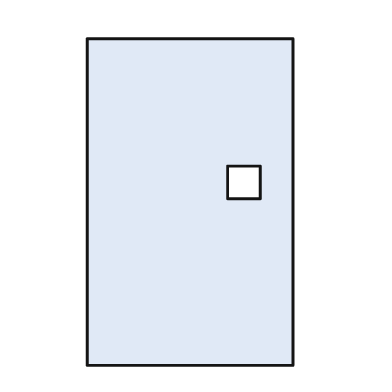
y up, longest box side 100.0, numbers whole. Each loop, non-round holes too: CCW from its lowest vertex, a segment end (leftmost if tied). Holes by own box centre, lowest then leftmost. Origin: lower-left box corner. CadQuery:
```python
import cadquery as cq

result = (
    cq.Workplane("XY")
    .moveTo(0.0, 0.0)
    .lineTo(63.0, 0.0)
    .lineTo(63.0, 100.0)
    .lineTo(0.0, 100.0)
    .close()
    .moveTo(43.0, 51.0)
    .lineTo(53.0, 51.0)
    .lineTo(53.0, 61.0)
    .lineTo(43.0, 61.0)
    .close()
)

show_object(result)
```